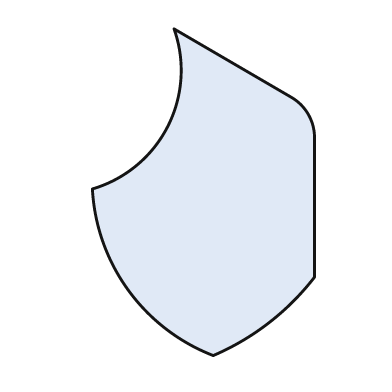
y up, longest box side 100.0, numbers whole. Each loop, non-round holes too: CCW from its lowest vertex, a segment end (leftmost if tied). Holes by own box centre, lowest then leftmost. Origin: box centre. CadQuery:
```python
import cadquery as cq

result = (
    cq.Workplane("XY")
    .moveTo(3.0, -50.0)
    .threePointArc((20.0, -40.0), (34.0, -26.0))
    .lineTo(34.0, 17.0)
    .threePointArc((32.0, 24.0), (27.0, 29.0))
    .lineTo(-9.0, 50.0)
    .threePointArc((-11.0, 20.0), (-34.0, 1.0))
    .threePointArc((-23.0, -30.0), (3.0, -50.0))
    .close()
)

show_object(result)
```